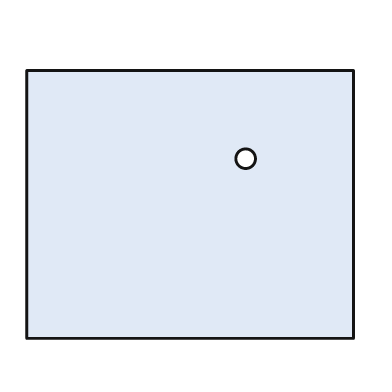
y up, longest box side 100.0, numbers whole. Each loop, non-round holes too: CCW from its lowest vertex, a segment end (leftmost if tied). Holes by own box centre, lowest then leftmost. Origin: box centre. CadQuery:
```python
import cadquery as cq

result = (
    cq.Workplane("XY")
    .moveTo(-50.0, -41.0)
    .lineTo(50.0, -41.0)
    .lineTo(50.0, 41.0)
    .lineTo(-50.0, 41.0)
    .close()
    .moveTo(17.0, 14.0)
    .circle(3.0)
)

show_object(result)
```